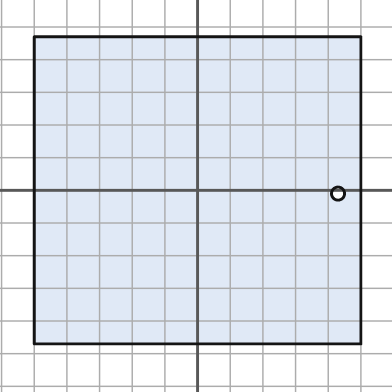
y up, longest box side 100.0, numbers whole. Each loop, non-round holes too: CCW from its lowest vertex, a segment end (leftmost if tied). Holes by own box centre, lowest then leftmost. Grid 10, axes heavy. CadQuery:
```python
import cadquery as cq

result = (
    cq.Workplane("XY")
    .moveTo(-50.0, -47.0)
    .lineTo(50.0, -47.0)
    .lineTo(50.0, 47.0)
    .lineTo(-50.0, 47.0)
    .close()
    .moveTo(43.0, -1.0)
    .circle(2.0)
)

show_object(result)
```